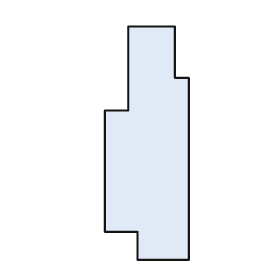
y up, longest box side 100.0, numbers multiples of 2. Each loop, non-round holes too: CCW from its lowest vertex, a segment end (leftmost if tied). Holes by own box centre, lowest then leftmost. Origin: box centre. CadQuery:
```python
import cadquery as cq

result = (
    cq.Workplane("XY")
    .moveTo(-4.0, -50.0)
    .lineTo(18.0, -50.0)
    .lineTo(18.0, 28.0)
    .lineTo(12.0, 28.0)
    .lineTo(12.0, 50.0)
    .lineTo(-8.0, 50.0)
    .lineTo(-8.0, 14.0)
    .lineTo(-18.0, 14.0)
    .lineTo(-18.0, -38.0)
    .lineTo(-4.0, -38.0)
    .close()
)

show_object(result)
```